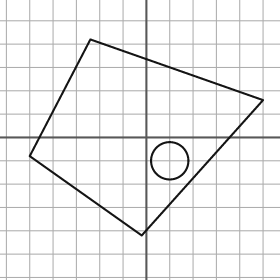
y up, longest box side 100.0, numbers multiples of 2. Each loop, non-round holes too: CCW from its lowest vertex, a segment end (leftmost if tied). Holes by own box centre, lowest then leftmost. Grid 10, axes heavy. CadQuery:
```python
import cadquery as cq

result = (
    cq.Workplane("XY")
    .moveTo(-2.0, -42.0)
    .lineTo(50.0, 16.0)
    .lineTo(-24.0, 42.0)
    .lineTo(-50.0, -8.0)
    .close()
    .moveTo(10.0, -10.0)
    .circle(8.0)
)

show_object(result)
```